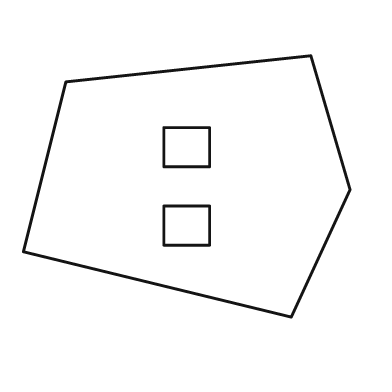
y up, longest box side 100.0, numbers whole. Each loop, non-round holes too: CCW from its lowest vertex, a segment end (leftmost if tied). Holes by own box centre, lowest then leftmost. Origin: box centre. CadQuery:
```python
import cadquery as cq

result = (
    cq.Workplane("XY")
    .moveTo(32.0, -40.0)
    .lineTo(50.0, -1.0)
    .lineTo(38.0, 40.0)
    .lineTo(-37.0, 32.0)
    .lineTo(-50.0, -20.0)
    .close()
    .moveTo(-7.0, -18.0)
    .lineTo(7.0, -18.0)
    .lineTo(7.0, -6.0)
    .lineTo(-7.0, -6.0)
    .close()
    .moveTo(-7.0, 6.0)
    .lineTo(7.0, 6.0)
    .lineTo(7.0, 18.0)
    .lineTo(-7.0, 18.0)
    .close()
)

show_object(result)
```